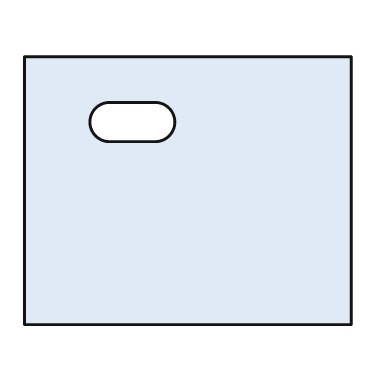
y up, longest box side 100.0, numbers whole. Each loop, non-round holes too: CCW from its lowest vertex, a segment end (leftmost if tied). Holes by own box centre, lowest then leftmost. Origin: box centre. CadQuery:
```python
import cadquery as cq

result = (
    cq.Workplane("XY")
    .moveTo(-50.0, -41.0)
    .lineTo(50.0, -41.0)
    .lineTo(50.0, 41.0)
    .lineTo(-50.0, 41.0)
    .close()
    .moveTo(-24.0, 15.0)
    .lineTo(-10.0, 15.0)
    .threePointArc((-4.0, 21.0), (-10.0, 27.0))
    .lineTo(-24.0, 27.0)
    .threePointArc((-30.0, 21.0), (-24.0, 15.0))
    .close()
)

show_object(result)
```